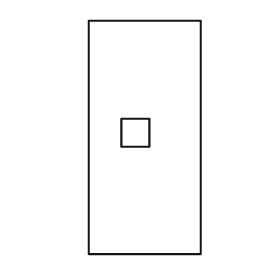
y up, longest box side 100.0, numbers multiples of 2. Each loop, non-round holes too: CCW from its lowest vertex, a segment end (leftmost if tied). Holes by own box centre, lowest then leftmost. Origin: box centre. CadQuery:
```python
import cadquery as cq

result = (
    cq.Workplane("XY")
    .moveTo(-24.0, -50.0)
    .lineTo(24.0, -50.0)
    .lineTo(24.0, 50.0)
    .lineTo(-24.0, 50.0)
    .close()
    .moveTo(-10.0, -4.0)
    .lineTo(2.0, -4.0)
    .lineTo(2.0, 8.0)
    .lineTo(-10.0, 8.0)
    .close()
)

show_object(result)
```